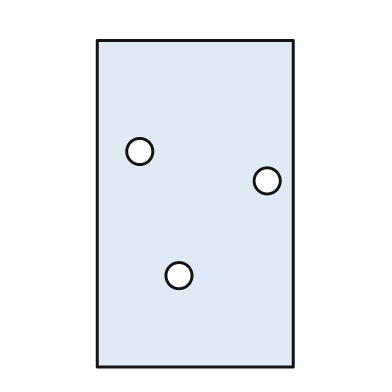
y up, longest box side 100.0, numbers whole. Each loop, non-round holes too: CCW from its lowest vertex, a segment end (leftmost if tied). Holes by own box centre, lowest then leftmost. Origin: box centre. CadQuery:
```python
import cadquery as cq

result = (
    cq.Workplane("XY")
    .moveTo(-30.0, -50.0)
    .lineTo(30.0, -50.0)
    .lineTo(30.0, 50.0)
    .lineTo(-30.0, 50.0)
    .close()
    .moveTo(-5.0, -22.0)
    .circle(4.0)
    .moveTo(22.0, 7.0)
    .circle(4.0)
    .moveTo(-17.0, 16.0)
    .circle(4.0)
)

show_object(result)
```